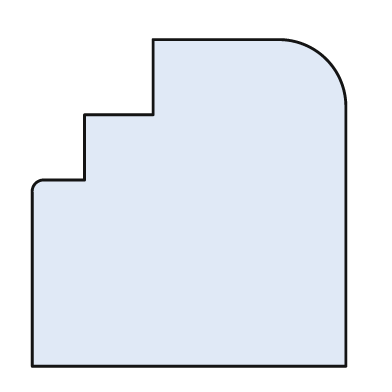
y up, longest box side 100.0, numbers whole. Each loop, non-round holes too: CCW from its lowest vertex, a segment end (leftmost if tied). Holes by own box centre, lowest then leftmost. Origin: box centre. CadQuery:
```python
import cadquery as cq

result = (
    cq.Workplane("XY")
    .moveTo(-48.0, -50.0)
    .lineTo(48.0, -50.0)
    .lineTo(48.0, 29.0)
    .threePointArc((42.0, 44.0), (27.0, 50.0))
    .lineTo(-11.0, 50.0)
    .lineTo(-11.0, 27.0)
    .lineTo(-32.0, 27.0)
    .lineTo(-32.0, 7.0)
    .lineTo(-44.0, 7.0)
    .threePointArc((-47.0, 6.0), (-48.0, 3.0))
    .close()
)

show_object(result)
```